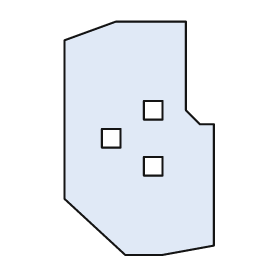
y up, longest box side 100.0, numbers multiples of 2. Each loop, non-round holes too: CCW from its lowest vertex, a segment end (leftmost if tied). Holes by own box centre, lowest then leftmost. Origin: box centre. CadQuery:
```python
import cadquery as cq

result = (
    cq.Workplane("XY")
    .moveTo(-6.0, -50.0)
    .lineTo(10.0, -50.0)
    .lineTo(32.0, -46.0)
    .lineTo(32.0, 6.0)
    .lineTo(26.0, 6.0)
    .lineTo(20.0, 12.0)
    .lineTo(20.0, 50.0)
    .lineTo(-10.0, 50.0)
    .lineTo(-32.0, 42.0)
    .lineTo(-32.0, -26.0)
    .close()
    .moveTo(2.0, -16.0)
    .lineTo(10.0, -16.0)
    .lineTo(10.0, -8.0)
    .lineTo(2.0, -8.0)
    .close()
    .moveTo(-16.0, -4.0)
    .lineTo(-8.0, -4.0)
    .lineTo(-8.0, 4.0)
    .lineTo(-16.0, 4.0)
    .close()
    .moveTo(2.0, 8.0)
    .lineTo(10.0, 8.0)
    .lineTo(10.0, 16.0)
    .lineTo(2.0, 16.0)
    .close()
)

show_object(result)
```